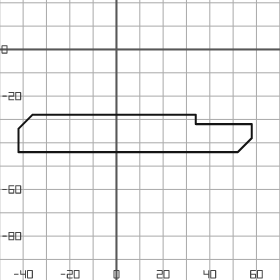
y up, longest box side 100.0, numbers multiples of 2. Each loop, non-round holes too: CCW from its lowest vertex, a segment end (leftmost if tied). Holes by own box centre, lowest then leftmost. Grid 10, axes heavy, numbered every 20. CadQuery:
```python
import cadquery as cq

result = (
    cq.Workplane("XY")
    .moveTo(-42.0, -44.0)
    .lineTo(52.0, -44.0)
    .lineTo(58.0, -38.0)
    .lineTo(58.0, -32.0)
    .lineTo(34.0, -32.0)
    .lineTo(34.0, -28.0)
    .lineTo(-36.0, -28.0)
    .lineTo(-42.0, -34.0)
    .close()
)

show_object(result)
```